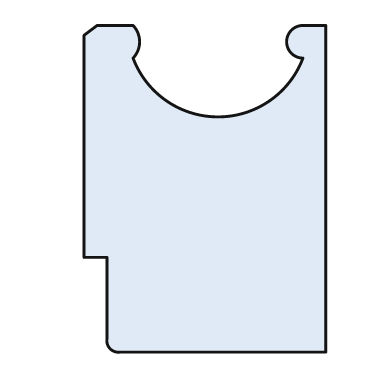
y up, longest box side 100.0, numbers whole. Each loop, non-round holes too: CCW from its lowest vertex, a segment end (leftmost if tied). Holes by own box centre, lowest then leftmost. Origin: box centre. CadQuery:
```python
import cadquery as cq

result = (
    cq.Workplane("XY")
    .moveTo(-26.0, -50.0)
    .lineTo(37.0, -50.0)
    .lineTo(37.0, 50.0)
    .lineTo(30.0, 50.0)
    .threePointArc((25.0, 45.0), (30.0, 40.0))
    .threePointArc((4.0, 22.0), (-22.0, 40.0))
    .threePointArc((-20.0, 45.0), (-22.0, 50.0))
    .lineTo(-33.0, 50.0)
    .lineTo(-37.0, 47.0)
    .lineTo(-37.0, -21.0)
    .lineTo(-30.0, -21.0)
    .lineTo(-30.0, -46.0)
    .threePointArc((-29.0, -49.0), (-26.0, -50.0))
    .close()
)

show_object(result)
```